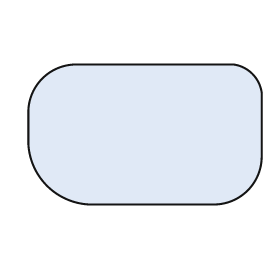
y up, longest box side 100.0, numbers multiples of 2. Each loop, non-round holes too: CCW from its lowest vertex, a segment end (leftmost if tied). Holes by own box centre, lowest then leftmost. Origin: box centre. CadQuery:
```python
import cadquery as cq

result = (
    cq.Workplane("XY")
    .moveTo(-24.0, -30.0)
    .lineTo(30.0, -30.0)
    .threePointArc((44.0, -24.0), (50.0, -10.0))
    .lineTo(50.0, 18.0)
    .threePointArc((46.0, 26.0), (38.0, 30.0))
    .lineTo(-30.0, 30.0)
    .threePointArc((-44.0, 24.0), (-50.0, 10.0))
    .lineTo(-50.0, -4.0)
    .threePointArc((-42.0, -22.0), (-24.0, -30.0))
    .close()
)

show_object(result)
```